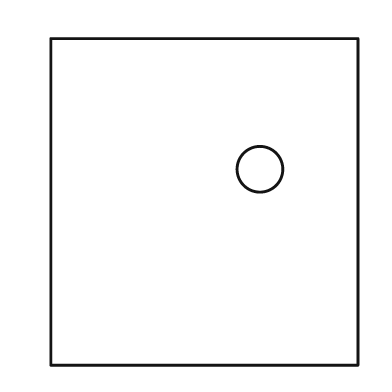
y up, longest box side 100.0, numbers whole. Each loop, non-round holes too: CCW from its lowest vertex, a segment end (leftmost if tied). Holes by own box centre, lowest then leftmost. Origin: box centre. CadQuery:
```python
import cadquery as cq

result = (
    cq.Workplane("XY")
    .moveTo(-47.0, -50.0)
    .lineTo(47.0, -50.0)
    .lineTo(47.0, 50.0)
    .lineTo(-47.0, 50.0)
    .close()
    .moveTo(17.0, 10.0)
    .circle(7.0)
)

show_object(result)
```